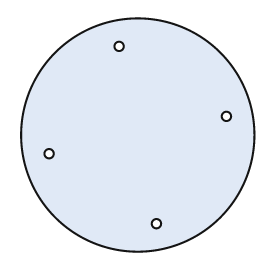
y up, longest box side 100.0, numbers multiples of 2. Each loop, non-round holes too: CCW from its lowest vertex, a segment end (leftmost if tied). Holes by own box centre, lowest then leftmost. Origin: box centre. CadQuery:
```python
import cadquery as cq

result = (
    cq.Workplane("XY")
    .moveTo(0.0, 0.0)
    .circle(50.0)
    .moveTo(8.0, -38.0)
    .circle(2.0)
    .moveTo(-38.0, -8.0)
    .circle(2.0)
    .moveTo(38.0, 8.0)
    .circle(2.0)
    .moveTo(-8.0, 38.0)
    .circle(2.0)
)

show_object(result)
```